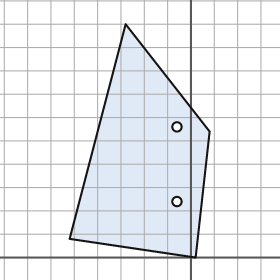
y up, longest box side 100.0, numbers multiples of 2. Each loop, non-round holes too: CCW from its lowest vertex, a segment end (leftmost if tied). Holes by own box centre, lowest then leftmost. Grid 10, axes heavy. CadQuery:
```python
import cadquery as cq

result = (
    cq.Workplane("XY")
    .moveTo(2.0, 0.0)
    .lineTo(8.0, 54.0)
    .lineTo(-28.0, 100.0)
    .lineTo(-52.0, 8.0)
    .close()
    .moveTo(-6.0, 24.0)
    .circle(2.0)
    .moveTo(-6.0, 56.0)
    .circle(2.0)
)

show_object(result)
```